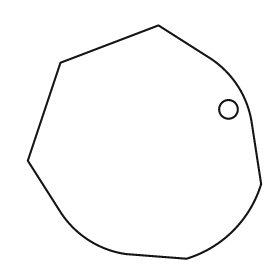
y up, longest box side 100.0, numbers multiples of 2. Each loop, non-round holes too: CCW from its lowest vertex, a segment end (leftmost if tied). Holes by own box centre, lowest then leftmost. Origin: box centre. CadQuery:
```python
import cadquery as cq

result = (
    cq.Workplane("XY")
    .moveTo(18.0, -50.0)
    .threePointArc((38.0, -38.0), (50.0, -18.0))
    .lineTo(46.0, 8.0)
    .threePointArc((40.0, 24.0), (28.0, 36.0))
    .lineTo(6.0, 50.0)
    .lineTo(-36.0, 34.0)
    .lineTo(-50.0, -8.0)
    .lineTo(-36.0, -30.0)
    .threePointArc((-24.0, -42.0), (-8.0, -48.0))
    .close()
    .moveTo(36.0, 14.0)
    .circle(4.0)
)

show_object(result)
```